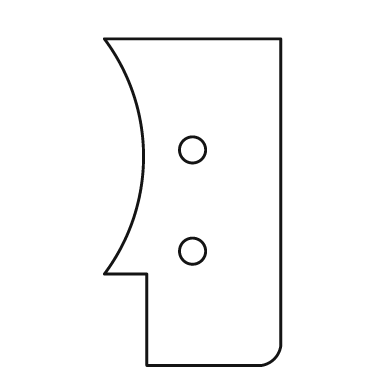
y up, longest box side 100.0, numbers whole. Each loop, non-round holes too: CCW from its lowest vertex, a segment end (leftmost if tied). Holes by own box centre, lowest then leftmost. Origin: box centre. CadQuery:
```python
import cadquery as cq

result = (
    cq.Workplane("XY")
    .moveTo(-14.0, -50.0)
    .lineTo(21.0, -50.0)
    .threePointArc((25.0, -48.0), (27.0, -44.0))
    .lineTo(27.0, 50.0)
    .lineTo(-27.0, 50.0)
    .threePointArc((-15.0, 14.0), (-27.0, -22.0))
    .lineTo(-14.0, -22.0)
    .close()
    .moveTo(0.0, -15.0)
    .circle(4.0)
    .moveTo(0.0, 16.0)
    .circle(4.0)
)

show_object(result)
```